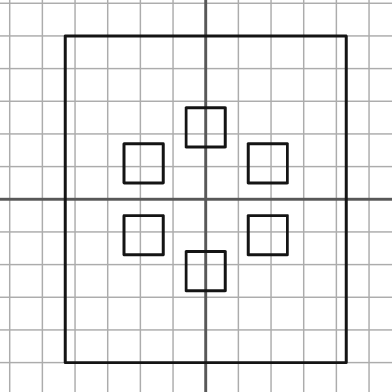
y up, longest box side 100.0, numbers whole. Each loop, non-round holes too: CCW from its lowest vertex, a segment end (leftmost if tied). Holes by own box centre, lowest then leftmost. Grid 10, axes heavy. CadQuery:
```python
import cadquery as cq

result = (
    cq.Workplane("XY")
    .moveTo(-43.0, -50.0)
    .lineTo(43.0, -50.0)
    .lineTo(43.0, 50.0)
    .lineTo(-43.0, 50.0)
    .close()
    .moveTo(-6.0, -28.0)
    .lineTo(6.0, -28.0)
    .lineTo(6.0, -16.0)
    .lineTo(-6.0, -16.0)
    .close()
    .moveTo(-25.0, -17.0)
    .lineTo(-13.0, -17.0)
    .lineTo(-13.0, -5.0)
    .lineTo(-25.0, -5.0)
    .close()
    .moveTo(13.0, -17.0)
    .lineTo(25.0, -17.0)
    .lineTo(25.0, -5.0)
    .lineTo(13.0, -5.0)
    .close()
    .moveTo(-25.0, 5.0)
    .lineTo(-13.0, 5.0)
    .lineTo(-13.0, 17.0)
    .lineTo(-25.0, 17.0)
    .close()
    .moveTo(13.0, 5.0)
    .lineTo(25.0, 5.0)
    .lineTo(25.0, 17.0)
    .lineTo(13.0, 17.0)
    .close()
    .moveTo(-6.0, 16.0)
    .lineTo(6.0, 16.0)
    .lineTo(6.0, 28.0)
    .lineTo(-6.0, 28.0)
    .close()
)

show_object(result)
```